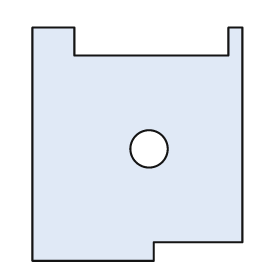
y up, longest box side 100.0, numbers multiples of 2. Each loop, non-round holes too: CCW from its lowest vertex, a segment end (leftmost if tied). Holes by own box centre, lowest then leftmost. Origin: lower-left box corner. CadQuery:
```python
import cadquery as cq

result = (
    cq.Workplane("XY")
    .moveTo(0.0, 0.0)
    .lineTo(52.0, 0.0)
    .lineTo(52.0, 8.0)
    .lineTo(90.0, 8.0)
    .lineTo(90.0, 100.0)
    .lineTo(84.0, 100.0)
    .lineTo(84.0, 88.0)
    .lineTo(18.0, 88.0)
    .lineTo(18.0, 100.0)
    .lineTo(0.0, 100.0)
    .close()
    .moveTo(50.0, 48.0)
    .circle(8.0)
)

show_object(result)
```